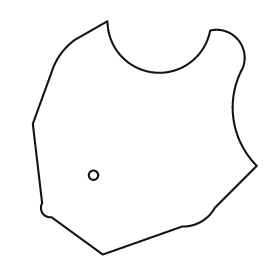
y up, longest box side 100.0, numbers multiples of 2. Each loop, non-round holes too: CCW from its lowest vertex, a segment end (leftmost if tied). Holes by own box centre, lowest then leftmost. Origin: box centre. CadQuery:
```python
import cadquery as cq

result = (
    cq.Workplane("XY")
    .moveTo(-18.0, -50.0)
    .lineTo(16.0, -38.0)
    .threePointArc((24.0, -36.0), (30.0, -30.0))
    .lineTo(48.0, -12.0)
    .threePointArc((38.0, 8.0), (42.0, 30.0))
    .threePointArc((40.0, 42.0), (28.0, 46.0))
    .threePointArc((4.0, 28.0), (-16.0, 50.0))
    .lineTo(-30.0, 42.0)
    .threePointArc((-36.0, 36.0), (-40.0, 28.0))
    .lineTo(-48.0, 6.0)
    .lineTo(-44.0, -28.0)
    .threePointArc((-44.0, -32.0), (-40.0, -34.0))
    .close()
    .moveTo(-22.0, -16.0)
    .circle(2.0)
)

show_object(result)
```